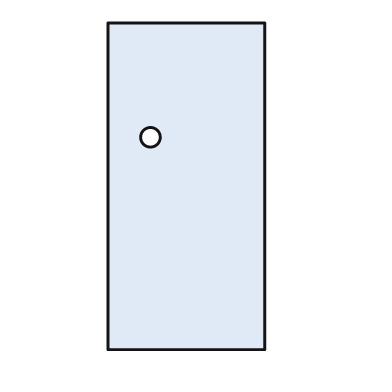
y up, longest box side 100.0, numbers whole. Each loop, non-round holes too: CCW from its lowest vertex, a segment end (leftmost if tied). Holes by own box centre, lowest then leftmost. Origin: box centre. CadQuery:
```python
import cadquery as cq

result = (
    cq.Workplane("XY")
    .moveTo(-24.0, -50.0)
    .lineTo(24.0, -50.0)
    .lineTo(24.0, 50.0)
    .lineTo(-24.0, 50.0)
    .close()
    .moveTo(-11.0, 15.0)
    .circle(3.0)
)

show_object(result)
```